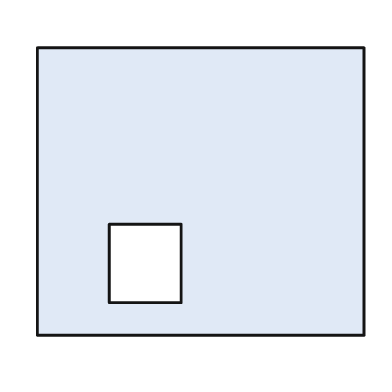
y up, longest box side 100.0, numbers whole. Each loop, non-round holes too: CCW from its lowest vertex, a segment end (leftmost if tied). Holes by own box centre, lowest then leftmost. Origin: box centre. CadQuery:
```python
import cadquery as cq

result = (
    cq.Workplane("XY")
    .moveTo(-50.0, -44.0)
    .lineTo(50.0, -44.0)
    .lineTo(50.0, 44.0)
    .lineTo(-50.0, 44.0)
    .close()
    .moveTo(-28.0, -34.0)
    .lineTo(-6.0, -34.0)
    .lineTo(-6.0, -10.0)
    .lineTo(-28.0, -10.0)
    .close()
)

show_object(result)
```